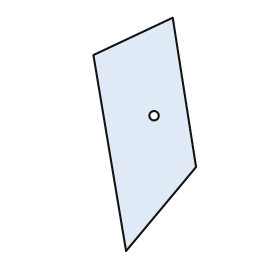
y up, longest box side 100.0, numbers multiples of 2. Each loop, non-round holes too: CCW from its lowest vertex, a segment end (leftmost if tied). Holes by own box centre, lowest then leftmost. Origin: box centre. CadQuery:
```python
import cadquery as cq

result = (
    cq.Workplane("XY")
    .moveTo(-8.0, -50.0)
    .lineTo(22.0, -14.0)
    .lineTo(12.0, 50.0)
    .lineTo(-22.0, 34.0)
    .close()
    .moveTo(4.0, 8.0)
    .circle(2.0)
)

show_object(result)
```